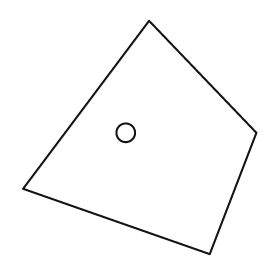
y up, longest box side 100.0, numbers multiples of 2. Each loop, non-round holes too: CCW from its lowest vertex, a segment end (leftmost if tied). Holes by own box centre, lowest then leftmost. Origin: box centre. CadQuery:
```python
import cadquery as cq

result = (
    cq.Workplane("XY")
    .moveTo(30.0, -50.0)
    .lineTo(50.0, 2.0)
    .lineTo(4.0, 50.0)
    .lineTo(-50.0, -22.0)
    .close()
    .moveTo(-6.0, 2.0)
    .circle(4.0)
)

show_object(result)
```